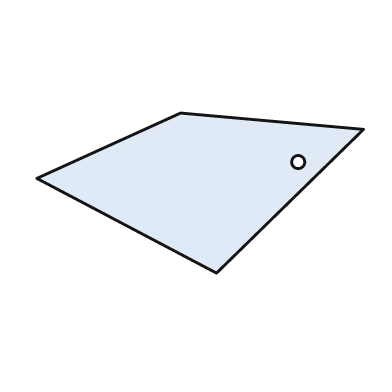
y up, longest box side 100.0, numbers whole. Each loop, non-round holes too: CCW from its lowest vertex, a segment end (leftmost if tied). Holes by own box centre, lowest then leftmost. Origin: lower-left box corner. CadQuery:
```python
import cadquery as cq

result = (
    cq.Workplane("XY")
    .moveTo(55.0, 0.0)
    .lineTo(100.0, 44.0)
    .lineTo(44.0, 49.0)
    .lineTo(0.0, 29.0)
    .close()
    .moveTo(80.0, 34.0)
    .circle(2.0)
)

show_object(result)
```